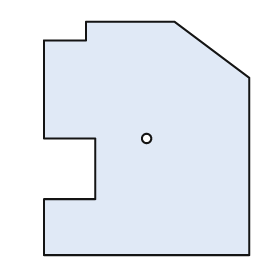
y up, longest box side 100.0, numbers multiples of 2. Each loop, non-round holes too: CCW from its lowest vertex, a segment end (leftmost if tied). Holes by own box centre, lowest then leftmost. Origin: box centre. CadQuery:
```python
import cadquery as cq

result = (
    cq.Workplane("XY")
    .moveTo(-44.0, -50.0)
    .lineTo(44.0, -50.0)
    .lineTo(44.0, 26.0)
    .lineTo(12.0, 50.0)
    .lineTo(-26.0, 50.0)
    .lineTo(-26.0, 42.0)
    .lineTo(-44.0, 42.0)
    .lineTo(-44.0, 0.0)
    .lineTo(-22.0, 0.0)
    .lineTo(-22.0, -26.0)
    .lineTo(-44.0, -26.0)
    .close()
    .moveTo(0.0, 0.0)
    .circle(2.0)
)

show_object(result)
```